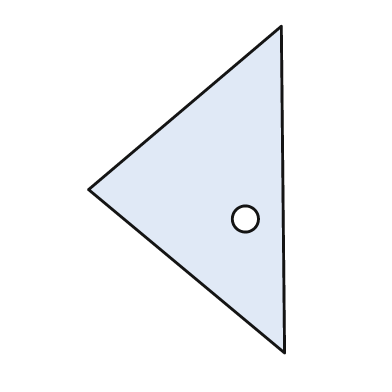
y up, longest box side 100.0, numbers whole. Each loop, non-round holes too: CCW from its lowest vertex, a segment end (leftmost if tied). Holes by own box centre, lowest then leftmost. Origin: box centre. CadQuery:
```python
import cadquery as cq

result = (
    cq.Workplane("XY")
    .moveTo(30.0, -50.0)
    .lineTo(29.0, 50.0)
    .lineTo(-30.0, 0.0)
    .close()
    .moveTo(18.0, -9.0)
    .circle(4.0)
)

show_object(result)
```